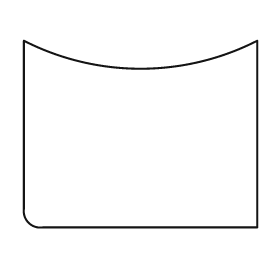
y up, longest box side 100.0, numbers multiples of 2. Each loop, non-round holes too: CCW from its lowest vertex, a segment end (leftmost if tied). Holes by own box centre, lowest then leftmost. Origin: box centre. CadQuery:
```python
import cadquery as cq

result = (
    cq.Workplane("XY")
    .moveTo(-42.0, -40.0)
    .lineTo(50.0, -40.0)
    .lineTo(50.0, 40.0)
    .threePointArc((0.0, 28.0), (-50.0, 40.0))
    .lineTo(-50.0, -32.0)
    .threePointArc((-48.0, -38.0), (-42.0, -40.0))
    .close()
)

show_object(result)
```